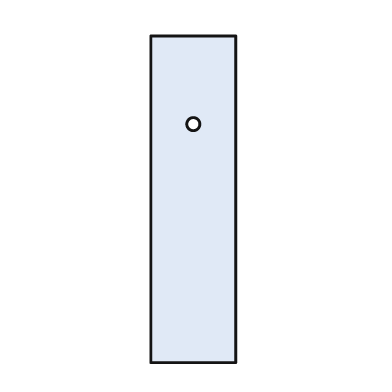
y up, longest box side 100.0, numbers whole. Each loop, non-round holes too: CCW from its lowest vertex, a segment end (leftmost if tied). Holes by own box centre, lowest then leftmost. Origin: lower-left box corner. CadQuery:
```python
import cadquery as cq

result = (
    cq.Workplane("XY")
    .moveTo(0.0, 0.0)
    .lineTo(26.0, 0.0)
    .lineTo(26.0, 100.0)
    .lineTo(0.0, 100.0)
    .close()
    .moveTo(13.0, 73.0)
    .circle(2.0)
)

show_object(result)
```